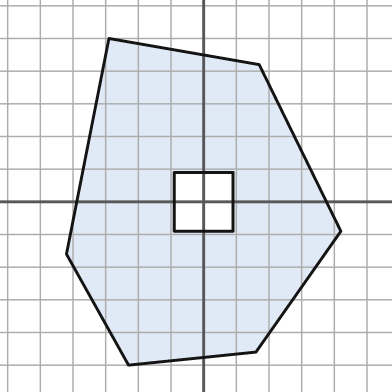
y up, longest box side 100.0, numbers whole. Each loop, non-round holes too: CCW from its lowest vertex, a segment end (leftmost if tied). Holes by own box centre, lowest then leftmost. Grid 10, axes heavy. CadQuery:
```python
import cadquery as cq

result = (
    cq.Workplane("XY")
    .moveTo(-23.0, -50.0)
    .lineTo(16.0, -46.0)
    .lineTo(42.0, -9.0)
    .lineTo(17.0, 42.0)
    .lineTo(-29.0, 50.0)
    .lineTo(-42.0, -16.0)
    .close()
    .moveTo(-9.0, -9.0)
    .lineTo(9.0, -9.0)
    .lineTo(9.0, 9.0)
    .lineTo(-9.0, 9.0)
    .close()
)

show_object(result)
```